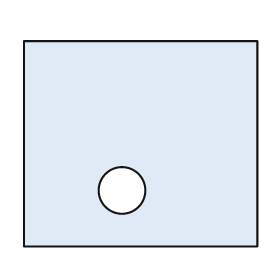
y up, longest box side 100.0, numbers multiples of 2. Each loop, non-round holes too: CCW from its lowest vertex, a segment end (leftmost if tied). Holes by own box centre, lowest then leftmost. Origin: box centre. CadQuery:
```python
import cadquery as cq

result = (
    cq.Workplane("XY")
    .moveTo(-50.0, -44.0)
    .lineTo(50.0, -44.0)
    .lineTo(50.0, 44.0)
    .lineTo(-50.0, 44.0)
    .close()
    .moveTo(-8.0, -20.0)
    .circle(10.0)
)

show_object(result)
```